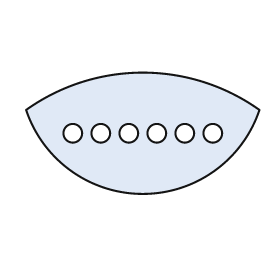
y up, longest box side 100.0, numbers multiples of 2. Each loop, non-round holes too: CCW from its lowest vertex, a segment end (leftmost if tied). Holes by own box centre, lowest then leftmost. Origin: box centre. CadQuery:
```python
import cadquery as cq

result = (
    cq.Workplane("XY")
    .moveTo(-50.0, 10.0)
    .threePointArc((0.0, -26.0), (50.0, 10.0))
    .threePointArc((0.0, 26.0), (-50.0, 10.0))
    .close()
    .moveTo(-30.0, 0.0)
    .circle(4.0)
    .moveTo(-18.0, 0.0)
    .circle(4.0)
    .moveTo(-6.0, 0.0)
    .circle(4.0)
    .moveTo(6.0, 0.0)
    .circle(4.0)
    .moveTo(18.0, 0.0)
    .circle(4.0)
    .moveTo(30.0, 0.0)
    .circle(4.0)
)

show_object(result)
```